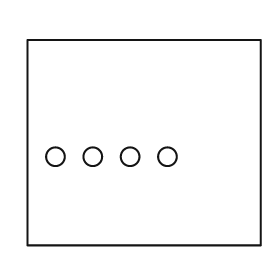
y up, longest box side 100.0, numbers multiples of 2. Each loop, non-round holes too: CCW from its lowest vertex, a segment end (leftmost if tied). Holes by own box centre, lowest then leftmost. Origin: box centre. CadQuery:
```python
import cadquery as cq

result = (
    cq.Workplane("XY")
    .moveTo(-50.0, -44.0)
    .lineTo(50.0, -44.0)
    .lineTo(50.0, 44.0)
    .lineTo(-50.0, 44.0)
    .close()
    .moveTo(-38.0, -6.0)
    .circle(4.0)
    .moveTo(-22.0, -6.0)
    .circle(4.0)
    .moveTo(-6.0, -6.0)
    .circle(4.0)
    .moveTo(10.0, -6.0)
    .circle(4.0)
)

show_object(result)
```